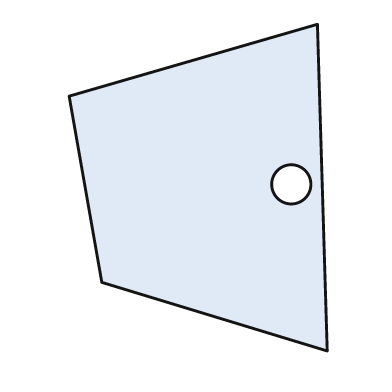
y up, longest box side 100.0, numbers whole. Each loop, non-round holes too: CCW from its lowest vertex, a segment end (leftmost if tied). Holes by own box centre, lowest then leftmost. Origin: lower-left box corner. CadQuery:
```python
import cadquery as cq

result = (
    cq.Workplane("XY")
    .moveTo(79.0, 0.0)
    .lineTo(76.0, 100.0)
    .lineTo(0.0, 78.0)
    .lineTo(10.0, 21.0)
    .close()
    .moveTo(68.0, 51.0)
    .circle(6.0)
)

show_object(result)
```